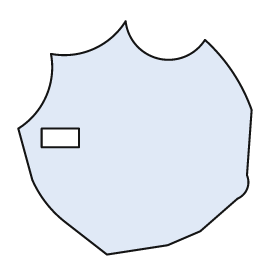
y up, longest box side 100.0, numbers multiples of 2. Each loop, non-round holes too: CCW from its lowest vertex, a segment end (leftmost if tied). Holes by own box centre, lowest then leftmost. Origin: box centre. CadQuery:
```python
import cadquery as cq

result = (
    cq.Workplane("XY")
    .moveTo(-12.0, -50.0)
    .lineTo(14.0, -46.0)
    .lineTo(28.0, -40.0)
    .lineTo(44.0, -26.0)
    .threePointArc((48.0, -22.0), (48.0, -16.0))
    .lineTo(50.0, 12.0)
    .threePointArc((42.0, 28.0), (30.0, 42.0))
    .threePointArc((10.0, 34.0), (-4.0, 50.0))
    .threePointArc((-18.0, 38.0), (-36.0, 36.0))
    .threePointArc((-38.0, 18.0), (-50.0, 4.0))
    .lineTo(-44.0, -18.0)
    .threePointArc((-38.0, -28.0), (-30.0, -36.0))
    .close()
    .moveTo(-40.0, -4.0)
    .lineTo(-24.0, -4.0)
    .lineTo(-24.0, 4.0)
    .lineTo(-40.0, 4.0)
    .close()
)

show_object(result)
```